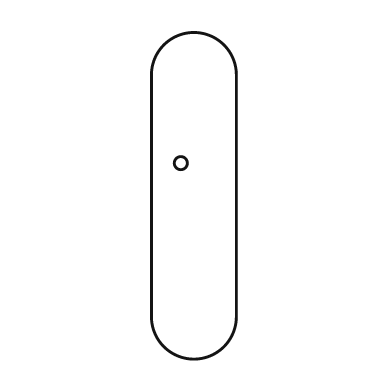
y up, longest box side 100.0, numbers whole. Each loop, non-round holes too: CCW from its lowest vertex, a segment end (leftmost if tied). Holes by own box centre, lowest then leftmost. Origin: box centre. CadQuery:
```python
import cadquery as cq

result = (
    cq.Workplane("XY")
    .moveTo(-13.0, -37.0)
    .threePointArc((0.0, -50.0), (13.0, -37.0))
    .lineTo(13.0, 37.0)
    .threePointArc((0.0, 50.0), (-13.0, 37.0))
    .close()
    .moveTo(-4.0, 10.0)
    .circle(2.0)
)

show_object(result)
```